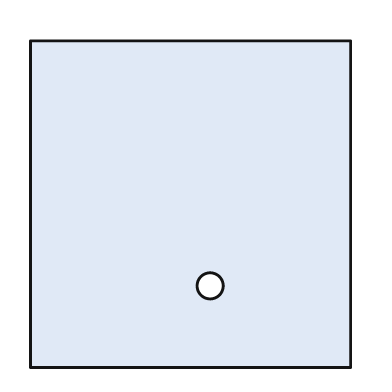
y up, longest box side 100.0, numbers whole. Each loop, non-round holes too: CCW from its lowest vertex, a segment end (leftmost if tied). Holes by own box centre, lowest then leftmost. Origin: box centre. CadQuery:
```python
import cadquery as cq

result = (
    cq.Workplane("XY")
    .moveTo(-49.0, -50.0)
    .lineTo(49.0, -50.0)
    .lineTo(49.0, 50.0)
    .lineTo(-49.0, 50.0)
    .close()
    .moveTo(6.0, -25.0)
    .circle(4.0)
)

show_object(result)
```